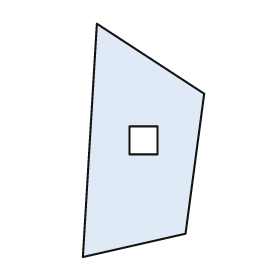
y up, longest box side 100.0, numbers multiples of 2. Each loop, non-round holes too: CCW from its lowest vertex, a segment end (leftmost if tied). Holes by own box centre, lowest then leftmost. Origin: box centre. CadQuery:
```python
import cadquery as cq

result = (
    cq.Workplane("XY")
    .moveTo(-26.0, -50.0)
    .lineTo(18.0, -40.0)
    .lineTo(26.0, 20.0)
    .lineTo(-20.0, 50.0)
    .close()
    .moveTo(-6.0, -6.0)
    .lineTo(6.0, -6.0)
    .lineTo(6.0, 6.0)
    .lineTo(-6.0, 6.0)
    .close()
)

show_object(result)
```